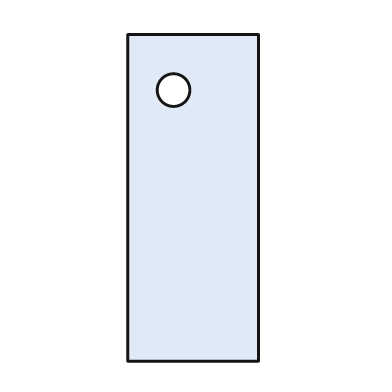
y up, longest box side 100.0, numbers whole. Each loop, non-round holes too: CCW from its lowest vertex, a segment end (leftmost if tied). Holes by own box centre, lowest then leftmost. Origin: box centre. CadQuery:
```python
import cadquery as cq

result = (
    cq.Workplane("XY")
    .moveTo(-20.0, -50.0)
    .lineTo(20.0, -50.0)
    .lineTo(20.0, 50.0)
    .lineTo(-20.0, 50.0)
    .close()
    .moveTo(-6.0, 33.0)
    .circle(5.0)
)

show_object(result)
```